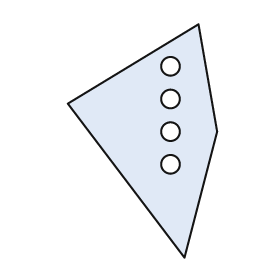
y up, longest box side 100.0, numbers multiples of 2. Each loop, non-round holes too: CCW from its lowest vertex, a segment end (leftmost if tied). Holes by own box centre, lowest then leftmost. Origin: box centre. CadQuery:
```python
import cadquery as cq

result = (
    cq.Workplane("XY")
    .moveTo(18.0, -50.0)
    .lineTo(32.0, 4.0)
    .lineTo(24.0, 50.0)
    .lineTo(-32.0, 16.0)
    .close()
    .moveTo(12.0, -10.0)
    .circle(4.0)
    .moveTo(12.0, 4.0)
    .circle(4.0)
    .moveTo(12.0, 18.0)
    .circle(4.0)
    .moveTo(12.0, 32.0)
    .circle(4.0)
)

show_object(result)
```